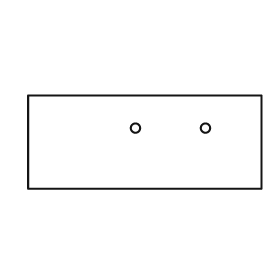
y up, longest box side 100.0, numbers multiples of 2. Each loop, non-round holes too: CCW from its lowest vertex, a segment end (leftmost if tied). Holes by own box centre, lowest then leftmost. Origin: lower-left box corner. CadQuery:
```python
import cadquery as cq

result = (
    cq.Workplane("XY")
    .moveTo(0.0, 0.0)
    .lineTo(100.0, 0.0)
    .lineTo(100.0, 40.0)
    .lineTo(0.0, 40.0)
    .close()
    .moveTo(46.0, 26.0)
    .circle(2.0)
    .moveTo(76.0, 26.0)
    .circle(2.0)
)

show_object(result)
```